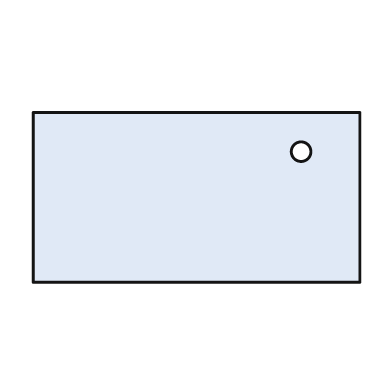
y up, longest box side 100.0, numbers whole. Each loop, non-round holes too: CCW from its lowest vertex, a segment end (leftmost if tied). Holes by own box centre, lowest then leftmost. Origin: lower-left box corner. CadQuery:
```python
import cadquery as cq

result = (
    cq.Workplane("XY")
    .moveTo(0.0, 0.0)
    .lineTo(100.0, 0.0)
    .lineTo(100.0, 52.0)
    .lineTo(0.0, 52.0)
    .close()
    .moveTo(82.0, 40.0)
    .circle(3.0)
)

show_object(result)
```